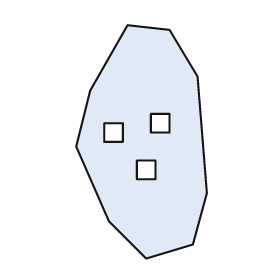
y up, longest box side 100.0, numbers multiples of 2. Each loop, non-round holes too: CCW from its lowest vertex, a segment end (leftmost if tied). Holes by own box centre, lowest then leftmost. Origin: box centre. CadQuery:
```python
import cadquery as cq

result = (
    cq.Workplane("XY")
    .moveTo(2.0, -50.0)
    .lineTo(22.0, -44.0)
    .lineTo(28.0, -22.0)
    .lineTo(24.0, 28.0)
    .lineTo(12.0, 48.0)
    .lineTo(-6.0, 50.0)
    .lineTo(-22.0, 22.0)
    .lineTo(-28.0, -2.0)
    .lineTo(-14.0, -34.0)
    .close()
    .moveTo(-2.0, -16.0)
    .lineTo(6.0, -16.0)
    .lineTo(6.0, -8.0)
    .lineTo(-2.0, -8.0)
    .close()
    .moveTo(-16.0, 0.0)
    .lineTo(-8.0, 0.0)
    .lineTo(-8.0, 8.0)
    .lineTo(-16.0, 8.0)
    .close()
    .moveTo(4.0, 4.0)
    .lineTo(12.0, 4.0)
    .lineTo(12.0, 12.0)
    .lineTo(4.0, 12.0)
    .close()
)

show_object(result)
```